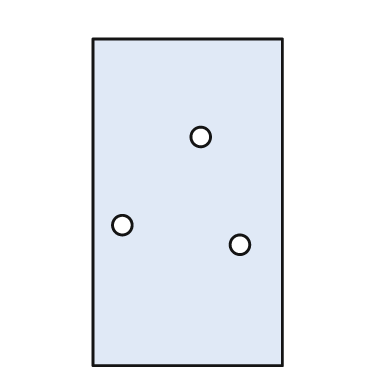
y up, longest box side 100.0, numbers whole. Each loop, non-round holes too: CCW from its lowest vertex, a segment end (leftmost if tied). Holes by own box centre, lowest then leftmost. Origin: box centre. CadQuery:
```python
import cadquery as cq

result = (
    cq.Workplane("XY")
    .moveTo(-29.0, -50.0)
    .lineTo(29.0, -50.0)
    .lineTo(29.0, 50.0)
    .lineTo(-29.0, 50.0)
    .close()
    .moveTo(16.0, -13.0)
    .circle(3.0)
    .moveTo(-20.0, -7.0)
    .circle(3.0)
    .moveTo(4.0, 20.0)
    .circle(3.0)
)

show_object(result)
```